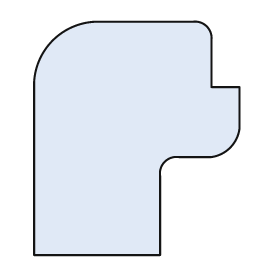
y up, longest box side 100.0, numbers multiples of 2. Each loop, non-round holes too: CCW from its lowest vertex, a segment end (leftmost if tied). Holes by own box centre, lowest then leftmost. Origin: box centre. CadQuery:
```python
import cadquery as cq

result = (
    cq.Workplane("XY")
    .moveTo(-44.0, -50.0)
    .lineTo(10.0, -50.0)
    .lineTo(10.0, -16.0)
    .threePointArc((12.0, -10.0), (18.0, -8.0))
    .lineTo(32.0, -8.0)
    .threePointArc((40.0, -4.0), (44.0, 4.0))
    .lineTo(44.0, 22.0)
    .lineTo(32.0, 22.0)
    .lineTo(32.0, 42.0)
    .threePointArc((30.0, 48.0), (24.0, 50.0))
    .lineTo(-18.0, 50.0)
    .threePointArc((-36.0, 42.0), (-44.0, 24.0))
    .close()
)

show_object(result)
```